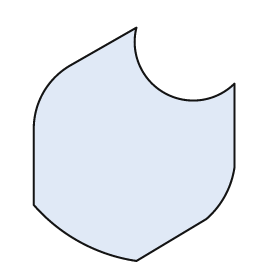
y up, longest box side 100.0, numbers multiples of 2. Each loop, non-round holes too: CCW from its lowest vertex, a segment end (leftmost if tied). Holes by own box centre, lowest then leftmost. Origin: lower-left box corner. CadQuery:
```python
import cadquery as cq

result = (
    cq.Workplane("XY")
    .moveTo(44.0, 0.0)
    .lineTo(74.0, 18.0)
    .threePointArc((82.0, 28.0), (86.0, 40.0))
    .lineTo(86.0, 76.0)
    .threePointArc((56.0, 72.0), (44.0, 100.0))
    .lineTo(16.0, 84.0)
    .threePointArc((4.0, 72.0), (0.0, 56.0))
    .lineTo(0.0, 24.0)
    .threePointArc((20.0, 8.0), (44.0, 0.0))
    .close()
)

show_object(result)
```